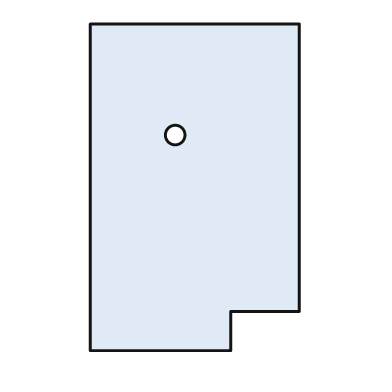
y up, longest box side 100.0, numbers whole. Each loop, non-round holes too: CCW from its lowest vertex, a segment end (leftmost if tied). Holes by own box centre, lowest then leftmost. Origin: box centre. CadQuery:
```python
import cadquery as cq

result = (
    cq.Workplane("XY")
    .moveTo(-32.0, -50.0)
    .lineTo(11.0, -50.0)
    .lineTo(11.0, -38.0)
    .lineTo(32.0, -38.0)
    .lineTo(32.0, 50.0)
    .lineTo(-32.0, 50.0)
    .close()
    .moveTo(-6.0, 16.0)
    .circle(3.0)
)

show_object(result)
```